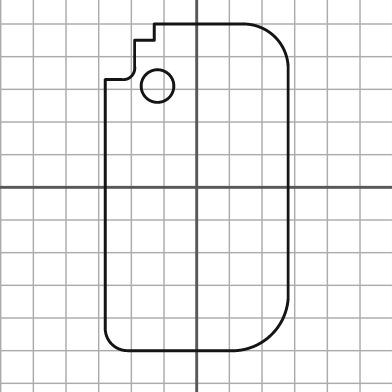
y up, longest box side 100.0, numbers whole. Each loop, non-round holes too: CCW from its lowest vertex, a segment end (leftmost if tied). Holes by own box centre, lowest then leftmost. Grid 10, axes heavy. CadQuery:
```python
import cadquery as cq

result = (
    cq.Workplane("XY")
    .moveTo(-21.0, -50.0)
    .lineTo(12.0, -50.0)
    .threePointArc((23.0, -45.0), (28.0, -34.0))
    .lineTo(28.0, 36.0)
    .threePointArc((24.0, 46.0), (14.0, 50.0))
    .lineTo(-13.0, 50.0)
    .lineTo(-13.0, 45.0)
    .lineTo(-19.0, 45.0)
    .lineTo(-19.0, 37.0)
    .threePointArc((-20.0, 34.0), (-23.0, 33.0))
    .lineTo(-28.0, 33.0)
    .lineTo(-28.0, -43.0)
    .threePointArc((-26.0, -48.0), (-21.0, -50.0))
    .close()
    .moveTo(-12.0, 31.0)
    .circle(5.0)
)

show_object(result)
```